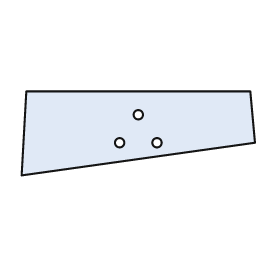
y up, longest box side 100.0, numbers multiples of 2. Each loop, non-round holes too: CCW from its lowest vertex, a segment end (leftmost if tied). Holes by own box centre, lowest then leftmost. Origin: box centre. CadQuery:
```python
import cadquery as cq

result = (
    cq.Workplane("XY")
    .moveTo(-50.0, -18.0)
    .lineTo(50.0, -4.0)
    .lineTo(48.0, 18.0)
    .lineTo(-48.0, 18.0)
    .close()
    .moveTo(-8.0, -4.0)
    .circle(2.0)
    .moveTo(8.0, -4.0)
    .circle(2.0)
    .moveTo(0.0, 8.0)
    .circle(2.0)
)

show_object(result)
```